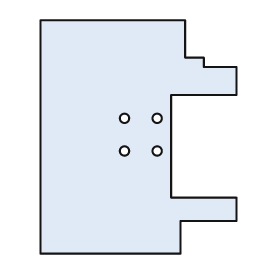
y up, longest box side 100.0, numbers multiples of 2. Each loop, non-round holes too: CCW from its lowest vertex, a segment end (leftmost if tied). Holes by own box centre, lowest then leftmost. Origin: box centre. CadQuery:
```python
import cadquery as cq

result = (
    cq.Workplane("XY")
    .moveTo(-42.0, -50.0)
    .lineTo(18.0, -50.0)
    .lineTo(18.0, -36.0)
    .lineTo(42.0, -36.0)
    .lineTo(42.0, -26.0)
    .lineTo(14.0, -26.0)
    .lineTo(14.0, 18.0)
    .lineTo(42.0, 18.0)
    .lineTo(42.0, 30.0)
    .lineTo(28.0, 30.0)
    .lineTo(28.0, 34.0)
    .lineTo(20.0, 34.0)
    .lineTo(20.0, 50.0)
    .lineTo(-42.0, 50.0)
    .close()
    .moveTo(-6.0, -6.0)
    .circle(2.0)
    .moveTo(8.0, -6.0)
    .circle(2.0)
    .moveTo(-6.0, 8.0)
    .circle(2.0)
    .moveTo(8.0, 8.0)
    .circle(2.0)
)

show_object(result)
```